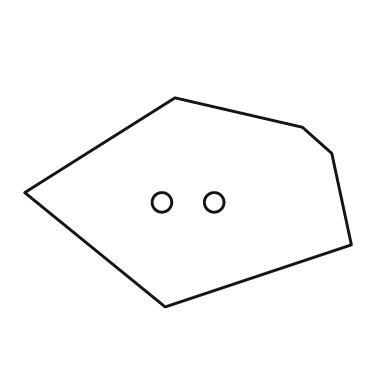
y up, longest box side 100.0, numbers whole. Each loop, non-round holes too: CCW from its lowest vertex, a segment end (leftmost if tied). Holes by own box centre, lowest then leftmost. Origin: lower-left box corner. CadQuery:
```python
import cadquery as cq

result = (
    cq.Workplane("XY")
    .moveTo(43.0, 0.0)
    .lineTo(100.0, 19.0)
    .lineTo(94.0, 47.0)
    .lineTo(85.0, 55.0)
    .lineTo(46.0, 64.0)
    .lineTo(0.0, 35.0)
    .close()
    .moveTo(42.0, 32.0)
    .circle(3.0)
    .moveTo(58.0, 32.0)
    .circle(3.0)
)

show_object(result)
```